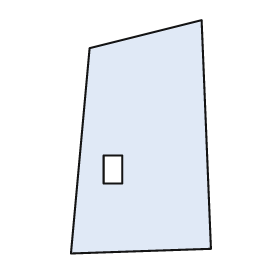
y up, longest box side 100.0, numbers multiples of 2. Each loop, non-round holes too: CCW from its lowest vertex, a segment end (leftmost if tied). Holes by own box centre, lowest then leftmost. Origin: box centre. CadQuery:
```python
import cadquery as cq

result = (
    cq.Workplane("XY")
    .moveTo(-30.0, -50.0)
    .lineTo(30.0, -48.0)
    .lineTo(26.0, 50.0)
    .lineTo(-22.0, 38.0)
    .close()
    .moveTo(-16.0, -20.0)
    .lineTo(-8.0, -20.0)
    .lineTo(-8.0, -8.0)
    .lineTo(-16.0, -8.0)
    .close()
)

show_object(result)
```